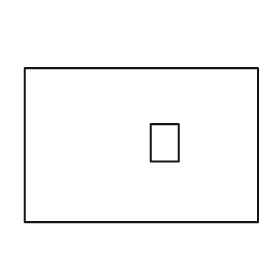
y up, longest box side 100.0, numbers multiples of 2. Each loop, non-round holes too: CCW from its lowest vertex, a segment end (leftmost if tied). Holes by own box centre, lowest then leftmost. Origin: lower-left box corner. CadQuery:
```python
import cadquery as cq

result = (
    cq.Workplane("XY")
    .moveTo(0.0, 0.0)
    .lineTo(100.0, 0.0)
    .lineTo(100.0, 66.0)
    .lineTo(0.0, 66.0)
    .close()
    .moveTo(54.0, 26.0)
    .lineTo(66.0, 26.0)
    .lineTo(66.0, 42.0)
    .lineTo(54.0, 42.0)
    .close()
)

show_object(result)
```